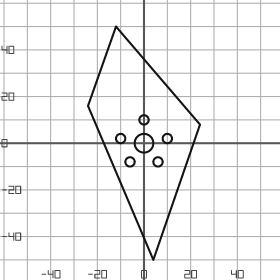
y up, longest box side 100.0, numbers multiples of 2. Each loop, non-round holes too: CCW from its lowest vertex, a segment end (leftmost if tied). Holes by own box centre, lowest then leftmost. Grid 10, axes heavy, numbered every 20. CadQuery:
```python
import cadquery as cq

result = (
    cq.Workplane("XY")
    .moveTo(4.0, -50.0)
    .lineTo(24.0, 8.0)
    .lineTo(-12.0, 50.0)
    .lineTo(-24.0, 16.0)
    .close()
    .moveTo(-6.0, -8.0)
    .circle(2.0)
    .moveTo(6.0, -8.0)
    .circle(2.0)
    .moveTo(0.0, 0.0)
    .circle(4.0)
    .moveTo(-10.0, 2.0)
    .circle(2.0)
    .moveTo(10.0, 2.0)
    .circle(2.0)
    .moveTo(0.0, 10.0)
    .circle(2.0)
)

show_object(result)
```